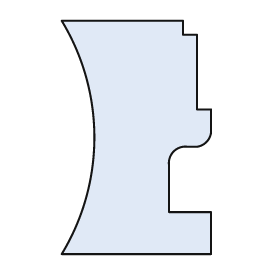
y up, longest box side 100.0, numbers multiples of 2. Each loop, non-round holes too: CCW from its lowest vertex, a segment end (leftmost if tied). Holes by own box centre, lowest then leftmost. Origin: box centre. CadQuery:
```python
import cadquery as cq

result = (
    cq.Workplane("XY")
    .moveTo(-32.0, -50.0)
    .lineTo(32.0, -50.0)
    .lineTo(32.0, -32.0)
    .lineTo(14.0, -32.0)
    .lineTo(14.0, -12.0)
    .threePointArc((16.0, -6.0), (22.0, -4.0))
    .lineTo(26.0, -4.0)
    .threePointArc((30.0, -2.0), (32.0, 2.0))
    .lineTo(32.0, 12.0)
    .lineTo(26.0, 12.0)
    .lineTo(26.0, 44.0)
    .lineTo(20.0, 44.0)
    .lineTo(20.0, 50.0)
    .lineTo(-32.0, 50.0)
    .threePointArc((-18.0, 0.0), (-32.0, -50.0))
    .close()
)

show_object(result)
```